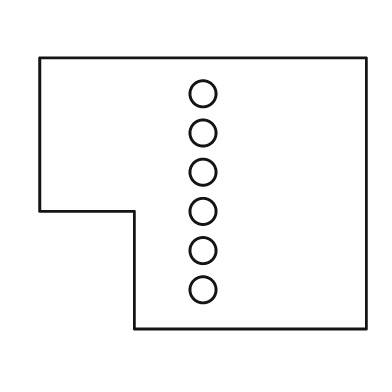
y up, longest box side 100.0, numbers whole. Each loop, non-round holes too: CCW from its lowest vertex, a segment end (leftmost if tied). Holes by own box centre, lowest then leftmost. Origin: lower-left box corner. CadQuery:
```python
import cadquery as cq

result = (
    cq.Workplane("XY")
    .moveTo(29.0, 0.0)
    .lineTo(100.0, 0.0)
    .lineTo(100.0, 83.0)
    .lineTo(0.0, 83.0)
    .lineTo(0.0, 36.0)
    .lineTo(29.0, 36.0)
    .close()
    .moveTo(50.0, 12.0)
    .circle(4.0)
    .moveTo(50.0, 24.0)
    .circle(4.0)
    .moveTo(50.0, 36.0)
    .circle(4.0)
    .moveTo(50.0, 48.0)
    .circle(4.0)
    .moveTo(50.0, 60.0)
    .circle(4.0)
    .moveTo(50.0, 72.0)
    .circle(4.0)
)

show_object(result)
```